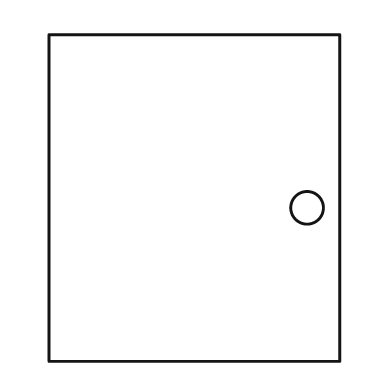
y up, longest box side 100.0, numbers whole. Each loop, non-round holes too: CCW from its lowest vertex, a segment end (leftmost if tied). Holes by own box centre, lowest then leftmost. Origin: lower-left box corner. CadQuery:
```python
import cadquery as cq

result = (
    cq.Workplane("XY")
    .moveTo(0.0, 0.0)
    .lineTo(89.0, 0.0)
    .lineTo(89.0, 100.0)
    .lineTo(0.0, 100.0)
    .close()
    .moveTo(79.0, 47.0)
    .circle(5.0)
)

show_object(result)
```